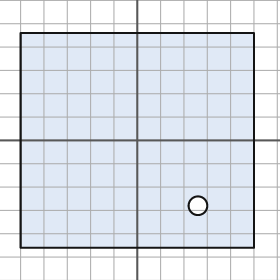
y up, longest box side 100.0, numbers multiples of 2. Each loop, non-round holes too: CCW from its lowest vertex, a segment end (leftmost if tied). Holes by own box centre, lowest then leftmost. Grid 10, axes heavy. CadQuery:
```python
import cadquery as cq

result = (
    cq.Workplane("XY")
    .moveTo(-50.0, -46.0)
    .lineTo(50.0, -46.0)
    .lineTo(50.0, 46.0)
    .lineTo(-50.0, 46.0)
    .close()
    .moveTo(26.0, -28.0)
    .circle(4.0)
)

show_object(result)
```